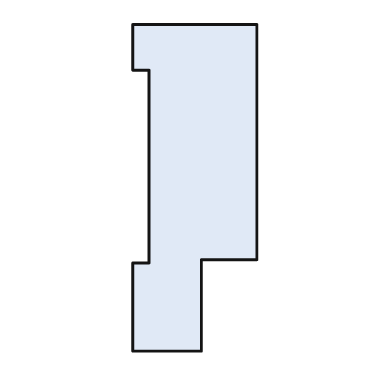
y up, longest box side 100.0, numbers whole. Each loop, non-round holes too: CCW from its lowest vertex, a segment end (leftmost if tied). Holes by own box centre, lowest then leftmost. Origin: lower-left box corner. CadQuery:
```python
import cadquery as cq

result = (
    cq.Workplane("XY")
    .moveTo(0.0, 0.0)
    .lineTo(21.0, 0.0)
    .lineTo(21.0, 28.0)
    .lineTo(38.0, 28.0)
    .lineTo(38.0, 100.0)
    .lineTo(0.0, 100.0)
    .lineTo(0.0, 86.0)
    .lineTo(5.0, 86.0)
    .lineTo(5.0, 27.0)
    .lineTo(0.0, 27.0)
    .close()
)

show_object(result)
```